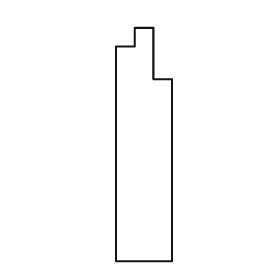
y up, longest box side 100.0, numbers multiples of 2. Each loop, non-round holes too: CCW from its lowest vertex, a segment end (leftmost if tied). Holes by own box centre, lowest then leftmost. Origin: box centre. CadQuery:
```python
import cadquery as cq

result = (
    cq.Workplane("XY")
    .moveTo(-12.0, -50.0)
    .lineTo(12.0, -50.0)
    .lineTo(12.0, 28.0)
    .lineTo(4.0, 28.0)
    .lineTo(4.0, 50.0)
    .lineTo(-4.0, 50.0)
    .lineTo(-4.0, 42.0)
    .lineTo(-12.0, 42.0)
    .close()
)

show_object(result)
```